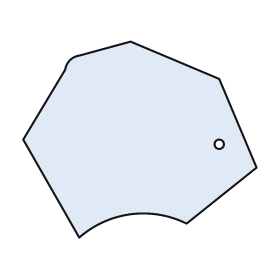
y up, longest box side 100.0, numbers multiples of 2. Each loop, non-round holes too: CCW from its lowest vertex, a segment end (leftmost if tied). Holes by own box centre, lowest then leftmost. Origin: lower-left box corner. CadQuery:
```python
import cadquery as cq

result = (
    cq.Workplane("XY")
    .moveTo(24.0, 0.0)
    .threePointArc((46.0, 10.0), (70.0, 6.0))
    .lineTo(100.0, 30.0)
    .lineTo(84.0, 68.0)
    .lineTo(46.0, 84.0)
    .lineTo(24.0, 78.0)
    .threePointArc((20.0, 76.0), (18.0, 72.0))
    .lineTo(0.0, 42.0)
    .close()
    .moveTo(84.0, 40.0)
    .circle(2.0)
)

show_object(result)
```